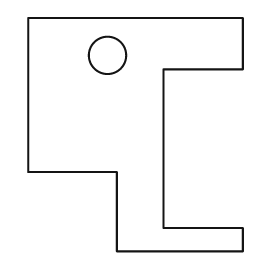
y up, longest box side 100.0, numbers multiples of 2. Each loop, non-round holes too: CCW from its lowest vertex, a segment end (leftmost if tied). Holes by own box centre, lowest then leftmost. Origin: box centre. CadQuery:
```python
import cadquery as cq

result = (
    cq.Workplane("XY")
    .moveTo(-8.0, -50.0)
    .lineTo(46.0, -50.0)
    .lineTo(46.0, -40.0)
    .lineTo(12.0, -40.0)
    .lineTo(12.0, 28.0)
    .lineTo(46.0, 28.0)
    .lineTo(46.0, 50.0)
    .lineTo(-46.0, 50.0)
    .lineTo(-46.0, -16.0)
    .lineTo(-8.0, -16.0)
    .close()
    .moveTo(-12.0, 34.0)
    .circle(8.0)
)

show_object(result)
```